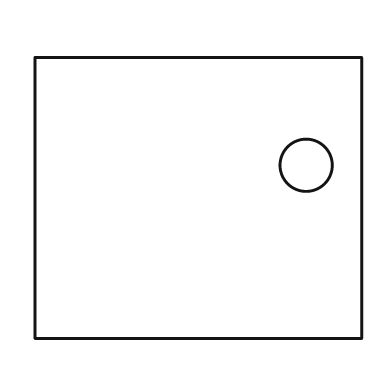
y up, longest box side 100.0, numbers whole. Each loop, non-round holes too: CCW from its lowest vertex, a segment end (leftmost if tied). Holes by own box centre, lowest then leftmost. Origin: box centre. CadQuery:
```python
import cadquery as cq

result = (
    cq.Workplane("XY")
    .moveTo(-50.0, -43.0)
    .lineTo(50.0, -43.0)
    .lineTo(50.0, 43.0)
    .lineTo(-50.0, 43.0)
    .close()
    .moveTo(33.0, 10.0)
    .circle(8.0)
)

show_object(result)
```